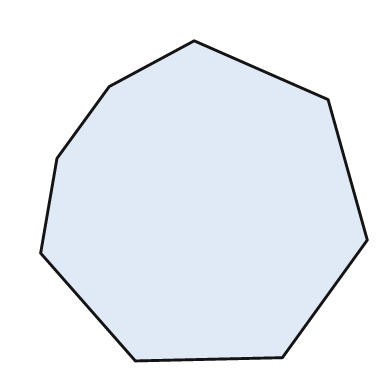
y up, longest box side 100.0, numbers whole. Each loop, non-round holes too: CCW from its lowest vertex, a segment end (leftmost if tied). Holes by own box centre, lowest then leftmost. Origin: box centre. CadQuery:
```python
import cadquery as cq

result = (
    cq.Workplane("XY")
    .moveTo(-21.0, -49.0)
    .lineTo(24.0, -48.0)
    .lineTo(50.0, -12.0)
    .lineTo(38.0, 31.0)
    .lineTo(-3.0, 49.0)
    .lineTo(-29.0, 35.0)
    .lineTo(-45.0, 13.0)
    .lineTo(-50.0, -16.0)
    .close()
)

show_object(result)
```